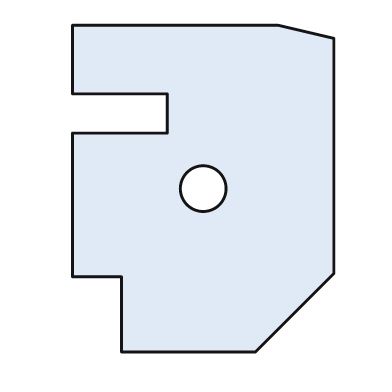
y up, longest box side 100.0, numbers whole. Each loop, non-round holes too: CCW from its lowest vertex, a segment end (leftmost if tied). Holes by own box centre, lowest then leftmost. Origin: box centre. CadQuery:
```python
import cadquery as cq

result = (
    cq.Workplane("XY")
    .moveTo(-25.0, -50.0)
    .lineTo(16.0, -50.0)
    .lineTo(40.0, -26.0)
    .lineTo(40.0, 46.0)
    .lineTo(23.0, 50.0)
    .lineTo(-40.0, 50.0)
    .lineTo(-40.0, 29.0)
    .lineTo(-11.0, 29.0)
    .lineTo(-11.0, 17.0)
    .lineTo(-40.0, 17.0)
    .lineTo(-40.0, -27.0)
    .lineTo(-25.0, -27.0)
    .close()
    .moveTo(0.0, 0.0)
    .circle(7.0)
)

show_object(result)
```